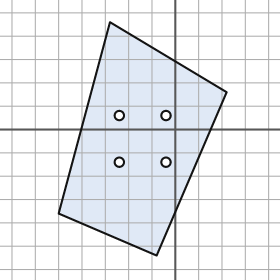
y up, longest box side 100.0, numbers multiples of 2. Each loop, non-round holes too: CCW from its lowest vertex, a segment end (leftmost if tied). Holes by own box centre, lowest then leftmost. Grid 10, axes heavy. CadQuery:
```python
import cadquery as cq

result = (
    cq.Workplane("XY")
    .moveTo(-8.0, -54.0)
    .lineTo(22.0, 16.0)
    .lineTo(-28.0, 46.0)
    .lineTo(-50.0, -36.0)
    .close()
    .moveTo(-24.0, -14.0)
    .circle(2.0)
    .moveTo(-4.0, -14.0)
    .circle(2.0)
    .moveTo(-24.0, 6.0)
    .circle(2.0)
    .moveTo(-4.0, 6.0)
    .circle(2.0)
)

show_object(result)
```